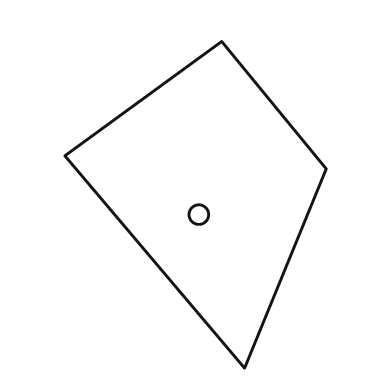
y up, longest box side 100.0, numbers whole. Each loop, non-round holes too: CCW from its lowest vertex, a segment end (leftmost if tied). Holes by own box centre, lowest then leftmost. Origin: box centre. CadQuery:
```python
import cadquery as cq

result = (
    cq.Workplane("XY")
    .moveTo(15.0, -50.0)
    .lineTo(40.0, 11.0)
    .lineTo(8.0, 50.0)
    .lineTo(-40.0, 15.0)
    .close()
    .moveTo(1.0, -3.0)
    .circle(3.0)
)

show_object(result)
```